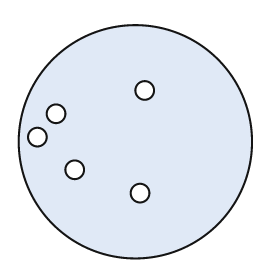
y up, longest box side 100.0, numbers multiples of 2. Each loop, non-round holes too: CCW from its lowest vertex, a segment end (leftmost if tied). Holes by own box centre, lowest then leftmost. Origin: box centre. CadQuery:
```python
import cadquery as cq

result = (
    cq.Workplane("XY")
    .moveTo(0.0, 0.0)
    .circle(50.0)
    .moveTo(2.0, -22.0)
    .circle(4.0)
    .moveTo(-26.0, -12.0)
    .circle(4.0)
    .moveTo(-42.0, 2.0)
    .circle(4.0)
    .moveTo(-34.0, 12.0)
    .circle(4.0)
    .moveTo(4.0, 22.0)
    .circle(4.0)
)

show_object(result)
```